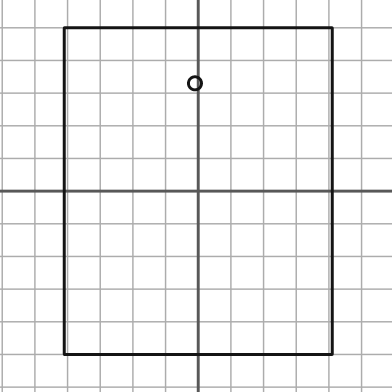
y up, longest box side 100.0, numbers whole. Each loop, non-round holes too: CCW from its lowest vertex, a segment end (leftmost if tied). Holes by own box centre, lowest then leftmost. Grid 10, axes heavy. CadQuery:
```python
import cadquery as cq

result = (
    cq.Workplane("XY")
    .moveTo(-41.0, -50.0)
    .lineTo(41.0, -50.0)
    .lineTo(41.0, 50.0)
    .lineTo(-41.0, 50.0)
    .close()
    .moveTo(-1.0, 33.0)
    .circle(2.0)
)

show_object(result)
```